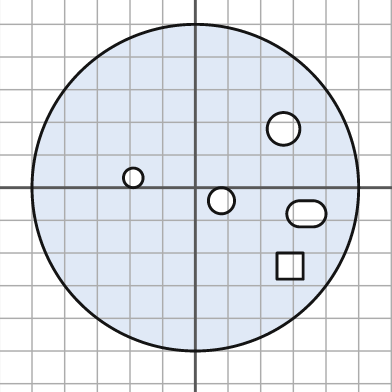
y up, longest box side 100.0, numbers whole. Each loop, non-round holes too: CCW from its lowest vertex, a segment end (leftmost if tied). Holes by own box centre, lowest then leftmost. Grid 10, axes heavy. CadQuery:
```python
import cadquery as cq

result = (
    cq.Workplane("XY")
    .moveTo(0.0, 0.0)
    .circle(50.0)
    .moveTo(25.0, -28.0)
    .lineTo(33.0, -28.0)
    .lineTo(33.0, -20.0)
    .lineTo(25.0, -20.0)
    .close()
    .moveTo(32.0, -12.0)
    .lineTo(36.0, -12.0)
    .threePointArc((40.0, -8.0), (36.0, -4.0))
    .lineTo(32.0, -4.0)
    .threePointArc((28.0, -8.0), (32.0, -12.0))
    .close()
    .moveTo(8.0, -4.0)
    .circle(4.0)
    .moveTo(-19.0, 3.0)
    .circle(3.0)
    .moveTo(27.0, 18.0)
    .circle(5.0)
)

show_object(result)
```